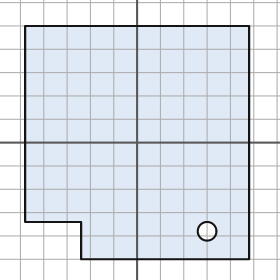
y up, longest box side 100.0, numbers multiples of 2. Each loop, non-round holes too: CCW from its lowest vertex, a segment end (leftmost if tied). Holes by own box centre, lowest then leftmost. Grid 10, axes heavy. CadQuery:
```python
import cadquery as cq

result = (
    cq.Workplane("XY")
    .moveTo(-24.0, -50.0)
    .lineTo(48.0, -50.0)
    .lineTo(48.0, 50.0)
    .lineTo(-48.0, 50.0)
    .lineTo(-48.0, -34.0)
    .lineTo(-24.0, -34.0)
    .close()
    .moveTo(30.0, -38.0)
    .circle(4.0)
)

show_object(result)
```